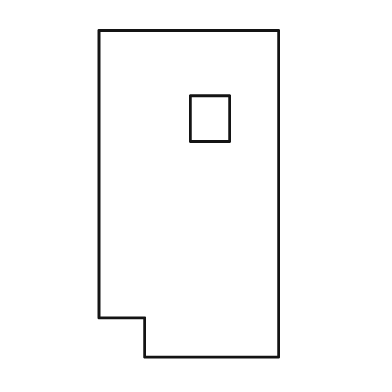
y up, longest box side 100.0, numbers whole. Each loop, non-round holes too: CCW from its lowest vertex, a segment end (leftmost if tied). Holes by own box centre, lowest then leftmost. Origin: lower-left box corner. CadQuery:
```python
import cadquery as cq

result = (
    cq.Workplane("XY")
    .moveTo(14.0, 0.0)
    .lineTo(55.0, 0.0)
    .lineTo(55.0, 100.0)
    .lineTo(0.0, 100.0)
    .lineTo(0.0, 12.0)
    .lineTo(14.0, 12.0)
    .close()
    .moveTo(28.0, 66.0)
    .lineTo(40.0, 66.0)
    .lineTo(40.0, 80.0)
    .lineTo(28.0, 80.0)
    .close()
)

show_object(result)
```